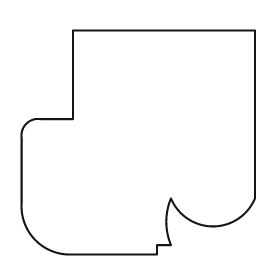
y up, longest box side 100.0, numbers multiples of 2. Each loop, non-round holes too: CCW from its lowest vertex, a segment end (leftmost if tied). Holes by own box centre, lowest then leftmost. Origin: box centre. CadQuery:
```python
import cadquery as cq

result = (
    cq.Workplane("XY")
    .moveTo(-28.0, -48.0)
    .lineTo(8.0, -48.0)
    .lineTo(8.0, -44.0)
    .lineTo(14.0, -44.0)
    .threePointArc((12.0, -34.0), (14.0, -24.0))
    .threePointArc((32.0, -36.0), (50.0, -24.0))
    .lineTo(50.0, 48.0)
    .lineTo(-28.0, 48.0)
    .lineTo(-28.0, 10.0)
    .lineTo(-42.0, 10.0)
    .threePointArc((-48.0, 8.0), (-50.0, 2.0))
    .lineTo(-50.0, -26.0)
    .threePointArc((-44.0, -42.0), (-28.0, -48.0))
    .close()
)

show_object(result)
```